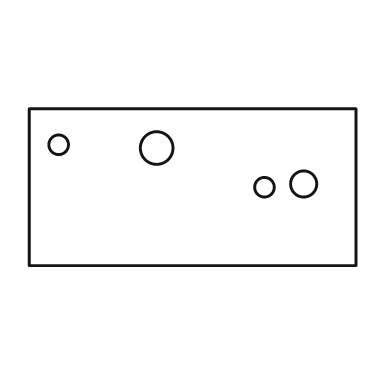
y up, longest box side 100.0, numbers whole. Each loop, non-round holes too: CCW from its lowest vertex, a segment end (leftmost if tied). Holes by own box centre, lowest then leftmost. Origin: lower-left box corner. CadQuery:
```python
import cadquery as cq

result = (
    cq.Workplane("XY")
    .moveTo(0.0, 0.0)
    .lineTo(100.0, 0.0)
    .lineTo(100.0, 48.0)
    .lineTo(0.0, 48.0)
    .close()
    .moveTo(72.0, 24.0)
    .circle(3.0)
    .moveTo(84.0, 25.0)
    .circle(4.0)
    .moveTo(39.0, 36.0)
    .circle(5.0)
    .moveTo(9.0, 37.0)
    .circle(3.0)
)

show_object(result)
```